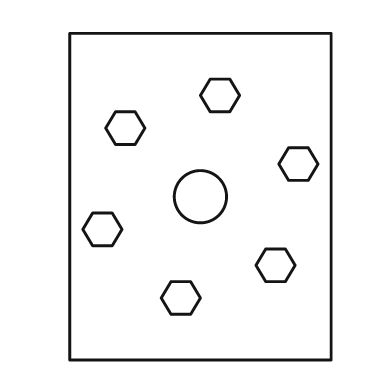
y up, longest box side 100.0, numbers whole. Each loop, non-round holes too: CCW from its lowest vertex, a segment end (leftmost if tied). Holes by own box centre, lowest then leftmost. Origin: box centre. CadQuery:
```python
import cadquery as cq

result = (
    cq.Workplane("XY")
    .moveTo(-40.0, -50.0)
    .lineTo(40.0, -50.0)
    .lineTo(40.0, 50.0)
    .lineTo(-40.0, 50.0)
    .close()
    .moveTo(-9.0, -36.0)
    .lineTo(-3.0, -36.0)
    .lineTo(0.0, -31.0)
    .lineTo(-3.0, -26.0)
    .lineTo(-9.0, -26.0)
    .lineTo(-12.0, -31.0)
    .close()
    .moveTo(20.0, -26.0)
    .lineTo(26.0, -26.0)
    .lineTo(29.0, -21.0)
    .lineTo(26.0, -16.0)
    .lineTo(20.0, -16.0)
    .lineTo(17.0, -21.0)
    .close()
    .moveTo(-33.0, -15.0)
    .lineTo(-27.0, -15.0)
    .lineTo(-24.0, -10.0)
    .lineTo(-27.0, -5.0)
    .lineTo(-33.0, -5.0)
    .lineTo(-36.0, -10.0)
    .close()
    .moveTo(0.0, 0.0)
    .circle(8.0)
    .moveTo(27.0, 5.0)
    .lineTo(33.0, 5.0)
    .lineTo(36.0, 10.0)
    .lineTo(33.0, 15.0)
    .lineTo(27.0, 15.0)
    .lineTo(24.0, 10.0)
    .close()
    .moveTo(-26.0, 16.0)
    .lineTo(-20.0, 16.0)
    .lineTo(-17.0, 21.0)
    .lineTo(-20.0, 26.0)
    .lineTo(-26.0, 26.0)
    .lineTo(-29.0, 21.0)
    .close()
    .moveTo(3.0, 26.0)
    .lineTo(9.0, 26.0)
    .lineTo(12.0, 31.0)
    .lineTo(9.0, 36.0)
    .lineTo(3.0, 36.0)
    .lineTo(0.0, 31.0)
    .close()
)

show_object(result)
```